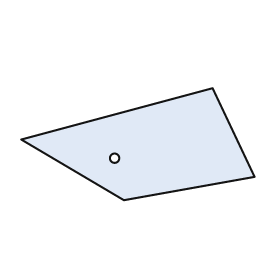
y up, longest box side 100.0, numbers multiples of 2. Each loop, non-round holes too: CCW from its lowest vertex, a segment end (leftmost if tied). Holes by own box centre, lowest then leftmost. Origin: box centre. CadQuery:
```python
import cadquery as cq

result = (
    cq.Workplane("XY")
    .moveTo(-6.0, -24.0)
    .lineTo(50.0, -14.0)
    .lineTo(32.0, 24.0)
    .lineTo(-50.0, 2.0)
    .close()
    .moveTo(-10.0, -6.0)
    .circle(2.0)
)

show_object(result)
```